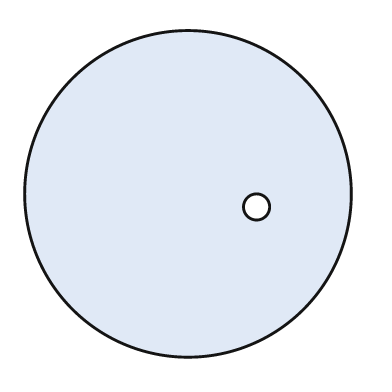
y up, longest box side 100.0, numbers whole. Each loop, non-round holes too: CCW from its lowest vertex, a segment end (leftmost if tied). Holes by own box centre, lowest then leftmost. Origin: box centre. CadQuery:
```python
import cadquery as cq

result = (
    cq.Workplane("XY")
    .moveTo(0.0, 0.0)
    .circle(50.0)
    .moveTo(21.0, -4.0)
    .circle(4.0)
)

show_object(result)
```